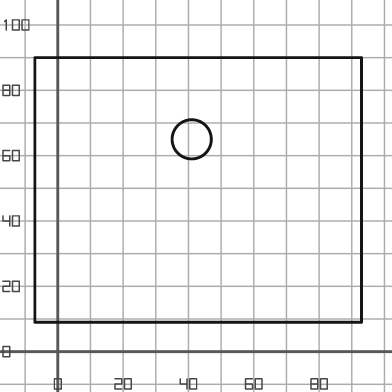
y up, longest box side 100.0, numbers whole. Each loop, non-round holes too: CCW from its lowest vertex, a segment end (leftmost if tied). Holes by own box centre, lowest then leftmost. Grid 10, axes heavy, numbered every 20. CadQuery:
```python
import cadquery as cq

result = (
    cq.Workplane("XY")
    .moveTo(-7.0, 9.0)
    .lineTo(93.0, 9.0)
    .lineTo(93.0, 90.0)
    .lineTo(-7.0, 90.0)
    .close()
    .moveTo(41.0, 65.0)
    .circle(6.0)
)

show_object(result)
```